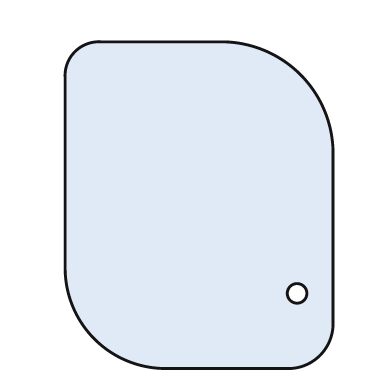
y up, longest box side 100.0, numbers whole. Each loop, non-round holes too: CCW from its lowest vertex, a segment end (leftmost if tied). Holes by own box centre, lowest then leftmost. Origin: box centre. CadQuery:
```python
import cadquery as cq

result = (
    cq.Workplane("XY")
    .moveTo(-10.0, -50.0)
    .lineTo(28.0, -50.0)
    .threePointArc((37.0, -46.0), (41.0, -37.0))
    .lineTo(41.0, 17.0)
    .threePointArc((31.0, 40.0), (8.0, 50.0))
    .lineTo(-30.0, 50.0)
    .threePointArc((-38.0, 47.0), (-41.0, 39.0))
    .lineTo(-41.0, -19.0)
    .threePointArc((-32.0, -41.0), (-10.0, -50.0))
    .close()
    .moveTo(30.0, -27.0)
    .circle(3.0)
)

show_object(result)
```